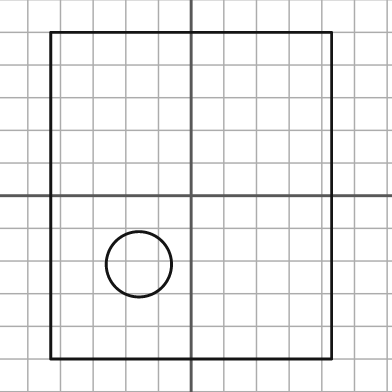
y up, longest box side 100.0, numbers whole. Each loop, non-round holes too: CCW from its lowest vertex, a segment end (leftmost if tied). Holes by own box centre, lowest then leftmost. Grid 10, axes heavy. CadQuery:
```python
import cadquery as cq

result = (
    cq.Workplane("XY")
    .moveTo(-43.0, -50.0)
    .lineTo(43.0, -50.0)
    .lineTo(43.0, 50.0)
    .lineTo(-43.0, 50.0)
    .close()
    .moveTo(-16.0, -21.0)
    .circle(10.0)
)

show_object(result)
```